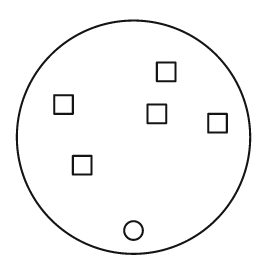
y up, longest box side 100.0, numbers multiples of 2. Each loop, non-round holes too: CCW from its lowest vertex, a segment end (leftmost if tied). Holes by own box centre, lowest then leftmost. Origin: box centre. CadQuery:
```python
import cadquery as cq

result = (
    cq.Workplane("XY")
    .moveTo(0.0, 0.0)
    .circle(50.0)
    .moveTo(0.0, -40.0)
    .circle(4.0)
    .moveTo(-26.0, -16.0)
    .lineTo(-18.0, -16.0)
    .lineTo(-18.0, -8.0)
    .lineTo(-26.0, -8.0)
    .close()
    .moveTo(32.0, 2.0)
    .lineTo(40.0, 2.0)
    .lineTo(40.0, 10.0)
    .lineTo(32.0, 10.0)
    .close()
    .moveTo(6.0, 6.0)
    .lineTo(14.0, 6.0)
    .lineTo(14.0, 14.0)
    .lineTo(6.0, 14.0)
    .close()
    .moveTo(-34.0, 10.0)
    .lineTo(-26.0, 10.0)
    .lineTo(-26.0, 18.0)
    .lineTo(-34.0, 18.0)
    .close()
    .moveTo(10.0, 24.0)
    .lineTo(18.0, 24.0)
    .lineTo(18.0, 32.0)
    .lineTo(10.0, 32.0)
    .close()
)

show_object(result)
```